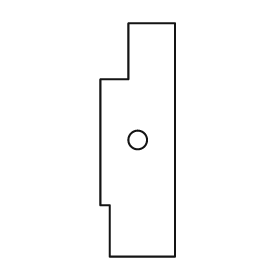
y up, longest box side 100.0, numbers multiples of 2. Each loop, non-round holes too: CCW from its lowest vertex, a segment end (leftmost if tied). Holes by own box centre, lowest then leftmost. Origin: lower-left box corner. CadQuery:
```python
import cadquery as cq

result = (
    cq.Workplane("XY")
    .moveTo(4.0, 0.0)
    .lineTo(32.0, 0.0)
    .lineTo(32.0, 100.0)
    .lineTo(12.0, 100.0)
    .lineTo(12.0, 76.0)
    .lineTo(0.0, 76.0)
    .lineTo(0.0, 22.0)
    .lineTo(4.0, 22.0)
    .close()
    .moveTo(16.0, 50.0)
    .circle(4.0)
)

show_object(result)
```